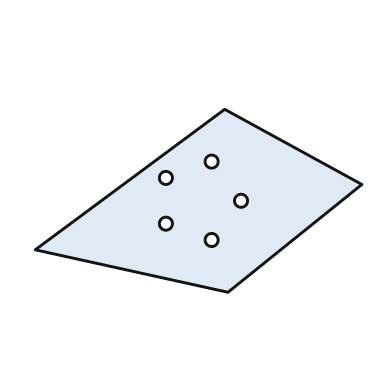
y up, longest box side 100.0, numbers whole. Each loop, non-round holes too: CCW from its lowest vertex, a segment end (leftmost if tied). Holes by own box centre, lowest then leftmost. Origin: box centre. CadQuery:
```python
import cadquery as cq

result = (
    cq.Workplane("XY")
    .moveTo(9.0, -28.0)
    .lineTo(50.0, 5.0)
    .lineTo(8.0, 28.0)
    .lineTo(-50.0, -15.0)
    .close()
    .moveTo(4.0, -12.0)
    .circle(2.0)
    .moveTo(-10.0, -7.0)
    .circle(2.0)
    .moveTo(13.0, 0.0)
    .circle(2.0)
    .moveTo(-10.0, 7.0)
    .circle(2.0)
    .moveTo(4.0, 12.0)
    .circle(2.0)
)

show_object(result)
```